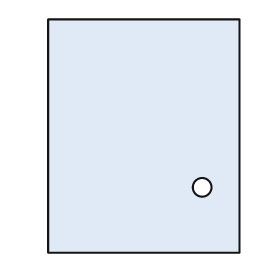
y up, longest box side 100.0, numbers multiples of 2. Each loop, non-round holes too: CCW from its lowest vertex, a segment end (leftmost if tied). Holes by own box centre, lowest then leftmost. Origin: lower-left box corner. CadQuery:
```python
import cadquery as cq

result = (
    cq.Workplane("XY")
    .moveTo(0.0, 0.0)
    .lineTo(82.0, 0.0)
    .lineTo(82.0, 100.0)
    .lineTo(0.0, 100.0)
    .close()
    .moveTo(66.0, 28.0)
    .circle(4.0)
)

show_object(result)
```